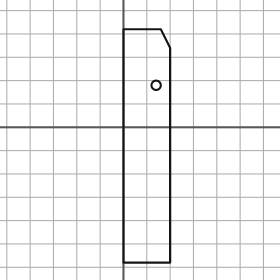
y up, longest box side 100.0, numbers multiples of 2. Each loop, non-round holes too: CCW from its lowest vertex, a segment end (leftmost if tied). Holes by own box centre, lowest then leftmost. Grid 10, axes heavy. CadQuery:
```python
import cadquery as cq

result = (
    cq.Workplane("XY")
    .moveTo(0.0, -58.0)
    .lineTo(20.0, -58.0)
    .lineTo(20.0, 34.0)
    .lineTo(16.0, 42.0)
    .lineTo(0.0, 42.0)
    .close()
    .moveTo(14.0, 18.0)
    .circle(2.0)
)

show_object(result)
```